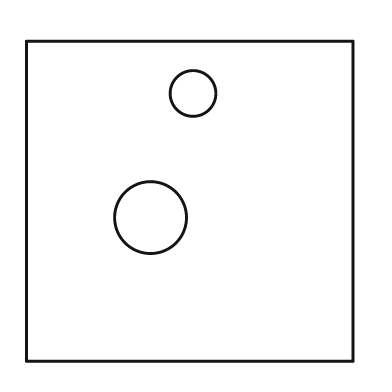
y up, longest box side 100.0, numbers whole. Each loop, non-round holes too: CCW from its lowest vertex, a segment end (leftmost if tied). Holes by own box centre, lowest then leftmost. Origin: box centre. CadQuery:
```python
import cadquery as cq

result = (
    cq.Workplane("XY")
    .moveTo(-50.0, -49.0)
    .lineTo(50.0, -49.0)
    .lineTo(50.0, 49.0)
    .lineTo(-50.0, 49.0)
    .close()
    .moveTo(-12.0, -5.0)
    .circle(11.0)
    .moveTo(1.0, 33.0)
    .circle(7.0)
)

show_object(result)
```